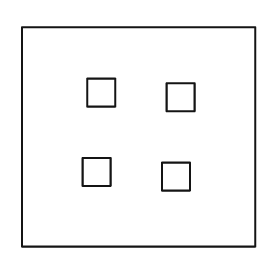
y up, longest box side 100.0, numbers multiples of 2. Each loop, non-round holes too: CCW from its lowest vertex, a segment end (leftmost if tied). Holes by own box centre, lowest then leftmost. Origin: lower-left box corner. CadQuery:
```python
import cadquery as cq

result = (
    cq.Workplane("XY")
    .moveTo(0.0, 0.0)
    .lineTo(100.0, 0.0)
    .lineTo(100.0, 94.0)
    .lineTo(0.0, 94.0)
    .close()
    .moveTo(60.0, 24.0)
    .lineTo(72.0, 24.0)
    .lineTo(72.0, 36.0)
    .lineTo(60.0, 36.0)
    .close()
    .moveTo(26.0, 26.0)
    .lineTo(38.0, 26.0)
    .lineTo(38.0, 38.0)
    .lineTo(26.0, 38.0)
    .close()
    .moveTo(62.0, 58.0)
    .lineTo(74.0, 58.0)
    .lineTo(74.0, 70.0)
    .lineTo(62.0, 70.0)
    .close()
    .moveTo(28.0, 60.0)
    .lineTo(40.0, 60.0)
    .lineTo(40.0, 72.0)
    .lineTo(28.0, 72.0)
    .close()
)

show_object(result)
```